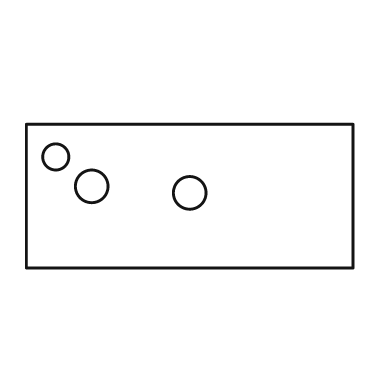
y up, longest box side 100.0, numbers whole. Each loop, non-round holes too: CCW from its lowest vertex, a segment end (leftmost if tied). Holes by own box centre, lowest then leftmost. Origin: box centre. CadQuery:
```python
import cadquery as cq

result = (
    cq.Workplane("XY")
    .moveTo(-50.0, -22.0)
    .lineTo(50.0, -22.0)
    .lineTo(50.0, 22.0)
    .lineTo(-50.0, 22.0)
    .close()
    .moveTo(0.0, 1.0)
    .circle(5.0)
    .moveTo(-30.0, 3.0)
    .circle(5.0)
    .moveTo(-41.0, 12.0)
    .circle(4.0)
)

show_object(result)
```